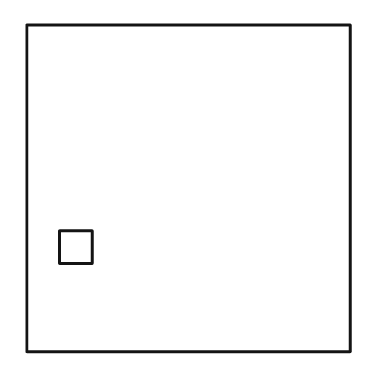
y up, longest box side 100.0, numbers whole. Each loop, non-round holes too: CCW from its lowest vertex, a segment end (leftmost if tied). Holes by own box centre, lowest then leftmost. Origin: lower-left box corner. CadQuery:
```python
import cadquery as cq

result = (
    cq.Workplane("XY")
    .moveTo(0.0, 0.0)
    .lineTo(99.0, 0.0)
    .lineTo(99.0, 100.0)
    .lineTo(0.0, 100.0)
    .close()
    .moveTo(10.0, 27.0)
    .lineTo(20.0, 27.0)
    .lineTo(20.0, 37.0)
    .lineTo(10.0, 37.0)
    .close()
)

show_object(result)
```